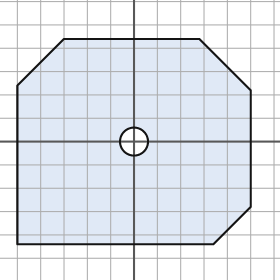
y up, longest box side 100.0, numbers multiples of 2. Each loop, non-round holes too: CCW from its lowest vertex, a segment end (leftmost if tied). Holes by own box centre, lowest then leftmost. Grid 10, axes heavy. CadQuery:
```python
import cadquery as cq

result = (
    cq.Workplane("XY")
    .moveTo(-50.0, -44.0)
    .lineTo(34.0, -44.0)
    .lineTo(50.0, -28.0)
    .lineTo(50.0, 22.0)
    .lineTo(28.0, 44.0)
    .lineTo(-30.0, 44.0)
    .lineTo(-50.0, 24.0)
    .close()
    .moveTo(0.0, 0.0)
    .circle(6.0)
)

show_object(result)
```